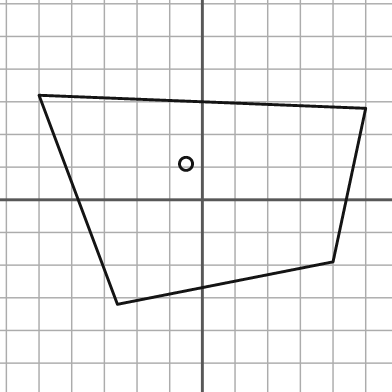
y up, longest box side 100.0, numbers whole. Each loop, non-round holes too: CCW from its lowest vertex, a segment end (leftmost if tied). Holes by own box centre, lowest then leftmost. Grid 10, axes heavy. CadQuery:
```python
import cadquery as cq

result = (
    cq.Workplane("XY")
    .moveTo(-26.0, -32.0)
    .lineTo(40.0, -19.0)
    .lineTo(50.0, 28.0)
    .lineTo(-50.0, 32.0)
    .close()
    .moveTo(-5.0, 11.0)
    .circle(2.0)
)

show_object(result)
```